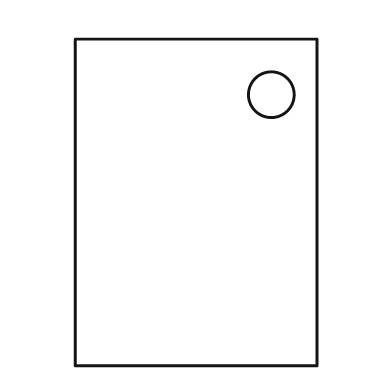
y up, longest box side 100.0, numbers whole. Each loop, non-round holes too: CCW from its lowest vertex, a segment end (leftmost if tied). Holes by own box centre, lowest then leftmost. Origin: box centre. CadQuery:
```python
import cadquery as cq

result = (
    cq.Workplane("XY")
    .moveTo(-37.0, -50.0)
    .lineTo(37.0, -50.0)
    .lineTo(37.0, 50.0)
    .lineTo(-37.0, 50.0)
    .close()
    .moveTo(23.0, 33.0)
    .circle(7.0)
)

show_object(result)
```